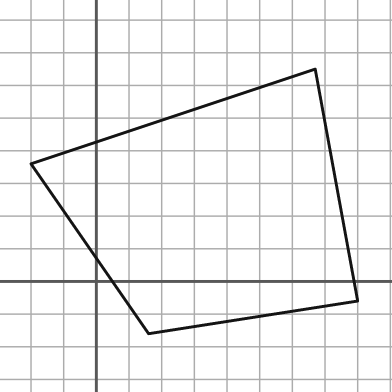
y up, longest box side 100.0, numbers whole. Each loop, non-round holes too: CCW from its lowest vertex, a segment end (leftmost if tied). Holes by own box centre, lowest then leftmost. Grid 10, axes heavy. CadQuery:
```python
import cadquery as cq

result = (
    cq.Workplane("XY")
    .moveTo(16.0, -16.0)
    .lineTo(80.0, -6.0)
    .lineTo(67.0, 65.0)
    .lineTo(-20.0, 36.0)
    .close()
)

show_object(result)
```